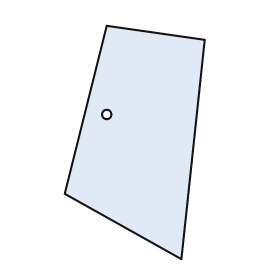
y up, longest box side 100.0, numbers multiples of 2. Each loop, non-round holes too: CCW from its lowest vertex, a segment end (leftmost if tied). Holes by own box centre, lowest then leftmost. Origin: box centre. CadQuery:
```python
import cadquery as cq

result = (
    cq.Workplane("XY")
    .moveTo(20.0, -50.0)
    .lineTo(30.0, 44.0)
    .lineTo(-12.0, 50.0)
    .lineTo(-30.0, -22.0)
    .close()
    .moveTo(-12.0, 12.0)
    .circle(2.0)
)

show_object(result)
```